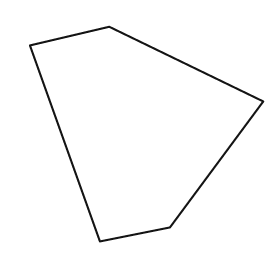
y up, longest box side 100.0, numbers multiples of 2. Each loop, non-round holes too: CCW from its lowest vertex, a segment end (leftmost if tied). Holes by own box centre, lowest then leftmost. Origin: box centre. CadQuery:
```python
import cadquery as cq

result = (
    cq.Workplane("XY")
    .moveTo(-20.0, -46.0)
    .lineTo(10.0, -40.0)
    .lineTo(50.0, 14.0)
    .lineTo(-16.0, 46.0)
    .lineTo(-50.0, 38.0)
    .close()
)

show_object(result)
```